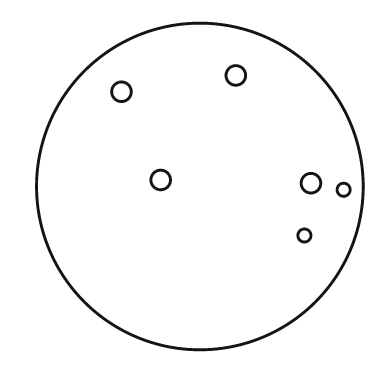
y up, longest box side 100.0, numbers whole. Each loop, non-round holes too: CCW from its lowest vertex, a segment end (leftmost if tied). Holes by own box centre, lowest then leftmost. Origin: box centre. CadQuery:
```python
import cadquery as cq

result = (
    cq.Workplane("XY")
    .moveTo(0.0, 0.0)
    .circle(50.0)
    .moveTo(32.0, -15.0)
    .circle(2.0)
    .moveTo(44.0, -1.0)
    .circle(2.0)
    .moveTo(34.0, 1.0)
    .circle(3.0)
    .moveTo(-12.0, 2.0)
    .circle(3.0)
    .moveTo(-24.0, 29.0)
    .circle(3.0)
    .moveTo(11.0, 34.0)
    .circle(3.0)
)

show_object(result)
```